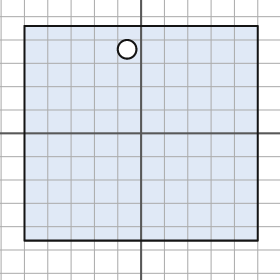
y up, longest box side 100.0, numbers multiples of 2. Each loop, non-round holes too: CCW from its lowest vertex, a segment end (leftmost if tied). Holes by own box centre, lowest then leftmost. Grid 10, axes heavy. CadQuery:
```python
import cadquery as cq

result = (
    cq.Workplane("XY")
    .moveTo(-50.0, -46.0)
    .lineTo(50.0, -46.0)
    .lineTo(50.0, 46.0)
    .lineTo(-50.0, 46.0)
    .close()
    .moveTo(-6.0, 36.0)
    .circle(4.0)
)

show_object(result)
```